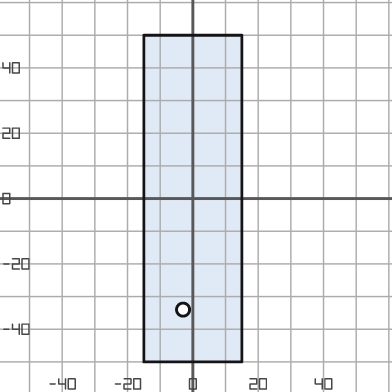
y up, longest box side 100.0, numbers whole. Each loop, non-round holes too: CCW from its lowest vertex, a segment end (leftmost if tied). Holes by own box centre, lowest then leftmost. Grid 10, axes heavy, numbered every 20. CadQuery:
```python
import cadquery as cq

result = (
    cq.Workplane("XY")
    .moveTo(-15.0, -50.0)
    .lineTo(15.0, -50.0)
    .lineTo(15.0, 50.0)
    .lineTo(-15.0, 50.0)
    .close()
    .moveTo(-3.0, -34.0)
    .circle(2.0)
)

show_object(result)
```